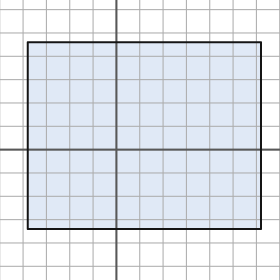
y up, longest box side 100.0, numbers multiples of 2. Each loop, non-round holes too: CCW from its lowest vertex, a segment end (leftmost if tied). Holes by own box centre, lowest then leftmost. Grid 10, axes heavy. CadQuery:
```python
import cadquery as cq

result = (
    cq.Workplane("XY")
    .moveTo(-38.0, -34.0)
    .lineTo(62.0, -34.0)
    .lineTo(62.0, 46.0)
    .lineTo(-38.0, 46.0)
    .close()
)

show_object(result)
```